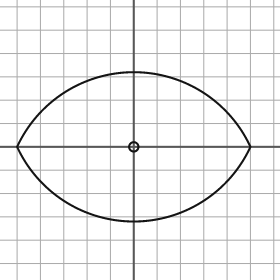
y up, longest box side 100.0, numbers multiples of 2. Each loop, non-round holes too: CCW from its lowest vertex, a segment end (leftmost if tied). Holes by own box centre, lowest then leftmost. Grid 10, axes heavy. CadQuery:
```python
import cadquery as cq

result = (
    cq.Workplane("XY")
    .moveTo(-50.0, 0.0)
    .threePointArc((0.0, -32.0), (50.0, 0.0))
    .threePointArc((0.0, 32.0), (-50.0, 0.0))
    .close()
    .moveTo(0.0, 0.0)
    .circle(2.0)
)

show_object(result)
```